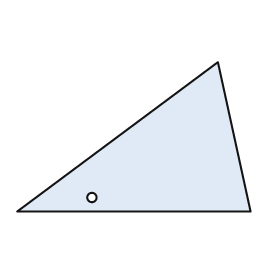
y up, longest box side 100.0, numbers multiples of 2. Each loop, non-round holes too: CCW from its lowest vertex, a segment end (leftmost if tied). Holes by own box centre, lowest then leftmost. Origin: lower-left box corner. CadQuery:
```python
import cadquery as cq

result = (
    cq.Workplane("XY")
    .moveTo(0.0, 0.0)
    .lineTo(100.0, 0.0)
    .lineTo(86.0, 64.0)
    .close()
    .moveTo(32.0, 6.0)
    .circle(2.0)
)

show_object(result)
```